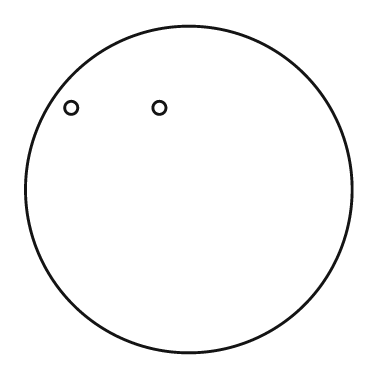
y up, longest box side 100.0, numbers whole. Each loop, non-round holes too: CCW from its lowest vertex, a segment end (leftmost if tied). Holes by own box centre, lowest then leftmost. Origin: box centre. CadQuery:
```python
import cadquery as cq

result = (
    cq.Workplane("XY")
    .moveTo(0.0, 0.0)
    .circle(50.0)
    .moveTo(-36.0, 25.0)
    .circle(2.0)
    .moveTo(-9.0, 25.0)
    .circle(2.0)
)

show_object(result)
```